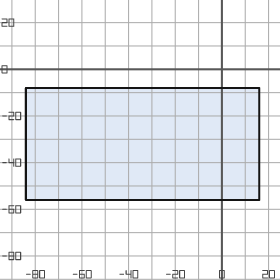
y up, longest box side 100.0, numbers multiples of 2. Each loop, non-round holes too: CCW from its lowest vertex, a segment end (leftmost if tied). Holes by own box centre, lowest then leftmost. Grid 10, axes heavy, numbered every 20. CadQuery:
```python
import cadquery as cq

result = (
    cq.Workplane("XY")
    .moveTo(-84.0, -56.0)
    .lineTo(16.0, -56.0)
    .lineTo(16.0, -8.0)
    .lineTo(-84.0, -8.0)
    .close()
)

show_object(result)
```